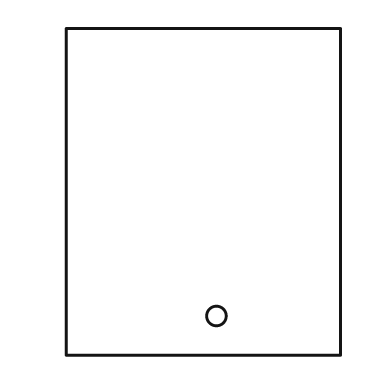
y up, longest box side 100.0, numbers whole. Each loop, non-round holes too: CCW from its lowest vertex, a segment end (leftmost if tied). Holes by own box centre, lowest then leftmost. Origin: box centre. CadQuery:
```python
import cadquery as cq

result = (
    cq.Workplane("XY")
    .moveTo(-42.0, -50.0)
    .lineTo(42.0, -50.0)
    .lineTo(42.0, 50.0)
    .lineTo(-42.0, 50.0)
    .close()
    .moveTo(4.0, -38.0)
    .circle(3.0)
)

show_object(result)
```